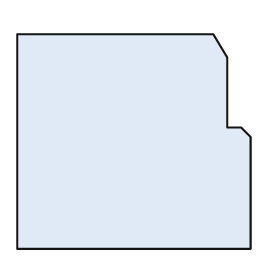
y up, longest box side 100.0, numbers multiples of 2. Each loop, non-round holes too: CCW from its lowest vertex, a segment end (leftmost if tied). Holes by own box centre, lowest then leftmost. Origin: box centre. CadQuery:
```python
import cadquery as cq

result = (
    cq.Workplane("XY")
    .moveTo(-50.0, -46.0)
    .lineTo(50.0, -46.0)
    .lineTo(50.0, 2.0)
    .lineTo(46.0, 6.0)
    .lineTo(40.0, 6.0)
    .lineTo(40.0, 36.0)
    .lineTo(34.0, 46.0)
    .lineTo(-50.0, 46.0)
    .close()
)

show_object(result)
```